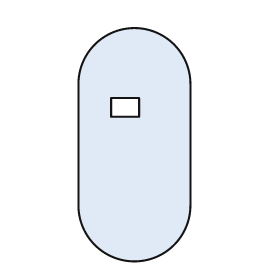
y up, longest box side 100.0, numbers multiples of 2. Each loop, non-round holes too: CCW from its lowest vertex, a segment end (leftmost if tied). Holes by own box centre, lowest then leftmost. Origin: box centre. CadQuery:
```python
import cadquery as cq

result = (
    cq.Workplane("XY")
    .moveTo(-24.0, -26.0)
    .threePointArc((0.0, -50.0), (24.0, -26.0))
    .lineTo(24.0, 26.0)
    .threePointArc((0.0, 50.0), (-24.0, 26.0))
    .close()
    .moveTo(-10.0, 12.0)
    .lineTo(2.0, 12.0)
    .lineTo(2.0, 20.0)
    .lineTo(-10.0, 20.0)
    .close()
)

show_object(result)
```